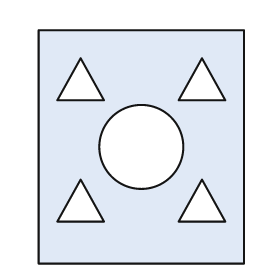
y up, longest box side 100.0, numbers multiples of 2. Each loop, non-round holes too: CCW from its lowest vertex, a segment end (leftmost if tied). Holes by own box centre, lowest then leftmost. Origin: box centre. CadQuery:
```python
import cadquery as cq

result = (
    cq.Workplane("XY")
    .moveTo(-44.0, -50.0)
    .lineTo(44.0, -50.0)
    .lineTo(44.0, 50.0)
    .lineTo(-44.0, 50.0)
    .close()
    .moveTo(-36.0, -32.0)
    .lineTo(-16.0, -32.0)
    .lineTo(-26.0, -14.0)
    .close()
    .moveTo(16.0, -32.0)
    .lineTo(36.0, -32.0)
    .lineTo(26.0, -14.0)
    .close()
    .moveTo(0.0, 0.0)
    .circle(18.0)
    .moveTo(-36.0, 20.0)
    .lineTo(-16.0, 20.0)
    .lineTo(-26.0, 38.0)
    .close()
    .moveTo(16.0, 20.0)
    .lineTo(36.0, 20.0)
    .lineTo(26.0, 38.0)
    .close()
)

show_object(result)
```